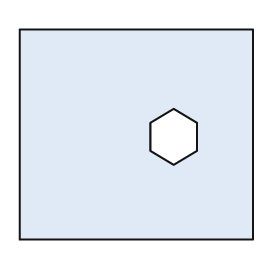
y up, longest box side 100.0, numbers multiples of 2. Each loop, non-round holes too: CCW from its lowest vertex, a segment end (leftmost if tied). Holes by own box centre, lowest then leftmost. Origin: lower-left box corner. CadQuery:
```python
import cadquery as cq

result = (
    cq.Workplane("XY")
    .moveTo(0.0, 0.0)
    .lineTo(100.0, 0.0)
    .lineTo(100.0, 90.0)
    .lineTo(0.0, 90.0)
    .close()
    .moveTo(66.0, 32.0)
    .lineTo(76.0, 38.0)
    .lineTo(76.0, 50.0)
    .lineTo(66.0, 56.0)
    .lineTo(56.0, 50.0)
    .lineTo(56.0, 38.0)
    .close()
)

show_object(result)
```